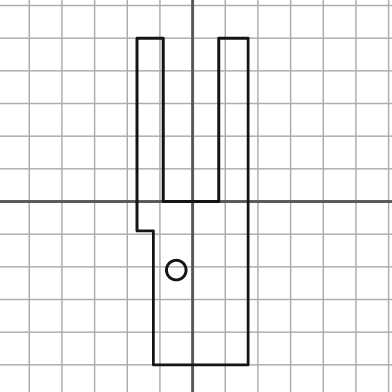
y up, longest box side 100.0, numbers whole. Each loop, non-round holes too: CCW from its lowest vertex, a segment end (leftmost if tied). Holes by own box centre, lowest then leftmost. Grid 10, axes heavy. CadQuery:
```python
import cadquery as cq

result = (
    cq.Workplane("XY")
    .moveTo(-12.0, -50.0)
    .lineTo(17.0, -50.0)
    .lineTo(17.0, 50.0)
    .lineTo(8.0, 50.0)
    .lineTo(8.0, 0.0)
    .lineTo(-9.0, 0.0)
    .lineTo(-9.0, 50.0)
    .lineTo(-17.0, 50.0)
    .lineTo(-17.0, -9.0)
    .lineTo(-12.0, -9.0)
    .close()
    .moveTo(-5.0, -21.0)
    .circle(3.0)
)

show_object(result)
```